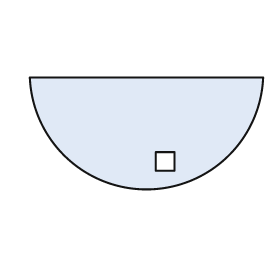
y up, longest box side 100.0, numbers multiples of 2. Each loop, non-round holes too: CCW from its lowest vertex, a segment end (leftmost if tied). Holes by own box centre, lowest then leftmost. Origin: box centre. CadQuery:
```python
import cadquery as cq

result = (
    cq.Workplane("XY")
    .moveTo(-50.0, 24.0)
    .threePointArc((0.0, -24.0), (50.0, 24.0))
    .close()
    .moveTo(4.0, -16.0)
    .lineTo(12.0, -16.0)
    .lineTo(12.0, -8.0)
    .lineTo(4.0, -8.0)
    .close()
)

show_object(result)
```